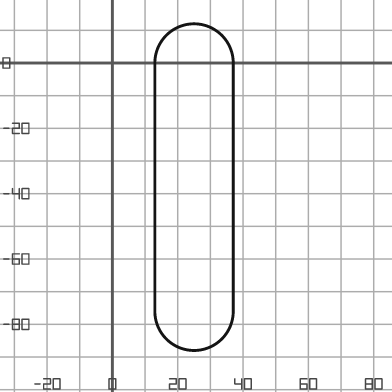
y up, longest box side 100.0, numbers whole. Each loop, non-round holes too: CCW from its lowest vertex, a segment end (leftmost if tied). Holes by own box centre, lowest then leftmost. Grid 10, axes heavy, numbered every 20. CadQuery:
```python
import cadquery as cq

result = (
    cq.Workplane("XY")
    .moveTo(13.0, -76.0)
    .threePointArc((25.0, -88.0), (37.0, -76.0))
    .lineTo(37.0, 0.0)
    .threePointArc((25.0, 12.0), (13.0, 0.0))
    .close()
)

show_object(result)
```